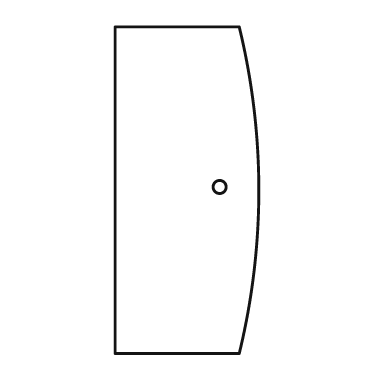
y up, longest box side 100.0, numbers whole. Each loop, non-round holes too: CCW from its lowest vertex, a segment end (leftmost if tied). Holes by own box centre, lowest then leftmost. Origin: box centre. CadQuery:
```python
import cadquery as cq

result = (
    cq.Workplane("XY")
    .moveTo(-22.0, -50.0)
    .lineTo(16.0, -50.0)
    .threePointArc((22.0, 0.0), (16.0, 50.0))
    .lineTo(-22.0, 50.0)
    .close()
    .moveTo(10.0, 1.0)
    .circle(2.0)
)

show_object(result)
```